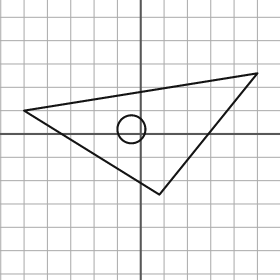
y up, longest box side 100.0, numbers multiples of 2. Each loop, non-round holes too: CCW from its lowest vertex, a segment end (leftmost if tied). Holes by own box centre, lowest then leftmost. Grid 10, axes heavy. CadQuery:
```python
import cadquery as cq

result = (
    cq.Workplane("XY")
    .moveTo(8.0, -26.0)
    .lineTo(50.0, 26.0)
    .lineTo(-50.0, 10.0)
    .close()
    .moveTo(-4.0, 2.0)
    .circle(6.0)
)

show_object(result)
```